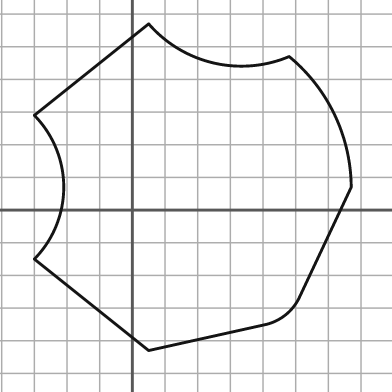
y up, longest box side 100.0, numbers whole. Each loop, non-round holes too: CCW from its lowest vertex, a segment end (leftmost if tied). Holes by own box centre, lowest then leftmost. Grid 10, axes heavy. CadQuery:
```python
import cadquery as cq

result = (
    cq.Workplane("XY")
    .moveTo(5.0, -43.0)
    .lineTo(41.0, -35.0)
    .threePointArc((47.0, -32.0), (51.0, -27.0))
    .lineTo(67.0, 7.0)
    .threePointArc((62.0, 29.0), (48.0, 47.0))
    .threePointArc((25.0, 45.0), (5.0, 57.0))
    .lineTo(-30.0, 29.0)
    .threePointArc((-21.0, 7.0), (-30.0, -15.0))
    .close()
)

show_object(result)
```